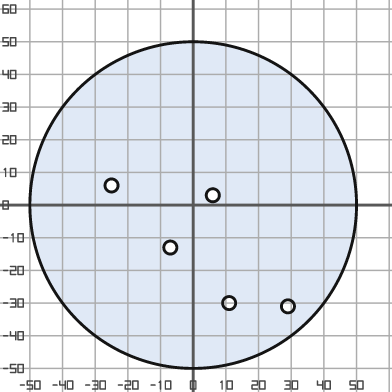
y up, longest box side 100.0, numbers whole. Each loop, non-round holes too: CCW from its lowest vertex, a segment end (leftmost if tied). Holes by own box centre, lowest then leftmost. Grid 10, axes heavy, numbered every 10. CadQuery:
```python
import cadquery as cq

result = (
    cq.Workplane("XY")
    .moveTo(0.0, 0.0)
    .circle(50.0)
    .moveTo(29.0, -31.0)
    .circle(2.0)
    .moveTo(11.0, -30.0)
    .circle(2.0)
    .moveTo(-7.0, -13.0)
    .circle(2.0)
    .moveTo(6.0, 3.0)
    .circle(2.0)
    .moveTo(-25.0, 6.0)
    .circle(2.0)
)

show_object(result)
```